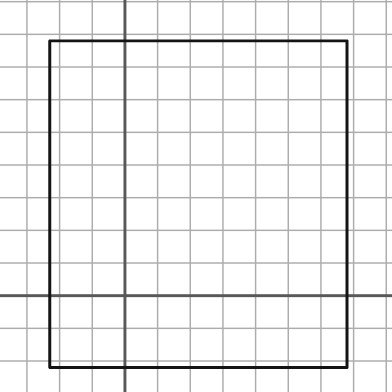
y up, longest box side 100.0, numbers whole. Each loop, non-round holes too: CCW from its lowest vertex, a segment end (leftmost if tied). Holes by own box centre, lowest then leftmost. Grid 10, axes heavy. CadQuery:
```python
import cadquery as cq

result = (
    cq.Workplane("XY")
    .moveTo(-23.0, -22.0)
    .lineTo(68.0, -22.0)
    .lineTo(68.0, 78.0)
    .lineTo(-23.0, 78.0)
    .close()
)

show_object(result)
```